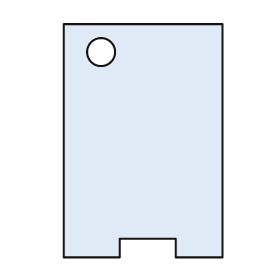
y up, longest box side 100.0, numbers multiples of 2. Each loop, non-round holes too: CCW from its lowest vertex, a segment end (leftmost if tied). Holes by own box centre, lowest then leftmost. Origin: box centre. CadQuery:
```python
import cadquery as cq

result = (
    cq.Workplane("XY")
    .moveTo(-34.0, -50.0)
    .lineTo(-10.0, -50.0)
    .lineTo(-10.0, -42.0)
    .lineTo(14.0, -42.0)
    .lineTo(14.0, -50.0)
    .lineTo(34.0, -50.0)
    .lineTo(34.0, 50.0)
    .lineTo(-34.0, 50.0)
    .close()
    .moveTo(-18.0, 38.0)
    .circle(6.0)
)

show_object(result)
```